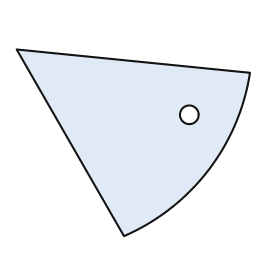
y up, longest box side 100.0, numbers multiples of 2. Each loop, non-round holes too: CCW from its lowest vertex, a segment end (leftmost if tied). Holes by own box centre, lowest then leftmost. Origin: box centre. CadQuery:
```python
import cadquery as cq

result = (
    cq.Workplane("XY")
    .moveTo(-4.0, -40.0)
    .threePointArc((32.0, -12.0), (50.0, 30.0))
    .lineTo(-50.0, 40.0)
    .close()
    .moveTo(24.0, 12.0)
    .circle(4.0)
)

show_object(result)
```